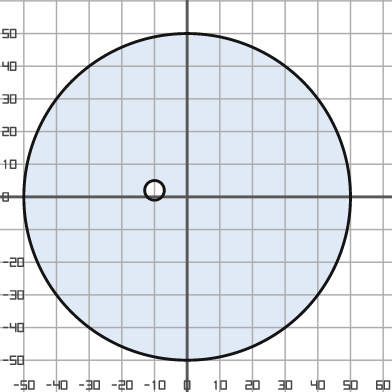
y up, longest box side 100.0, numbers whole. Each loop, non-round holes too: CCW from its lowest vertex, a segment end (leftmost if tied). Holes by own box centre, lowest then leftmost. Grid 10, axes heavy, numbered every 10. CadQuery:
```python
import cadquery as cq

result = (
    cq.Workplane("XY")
    .moveTo(0.0, 0.0)
    .circle(50.0)
    .moveTo(-10.0, 2.0)
    .circle(3.0)
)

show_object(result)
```